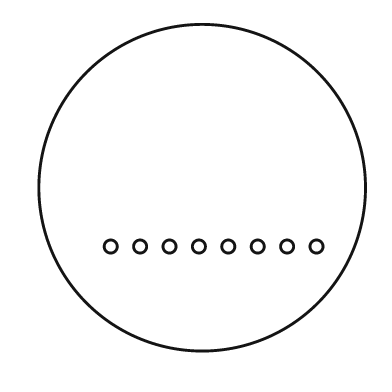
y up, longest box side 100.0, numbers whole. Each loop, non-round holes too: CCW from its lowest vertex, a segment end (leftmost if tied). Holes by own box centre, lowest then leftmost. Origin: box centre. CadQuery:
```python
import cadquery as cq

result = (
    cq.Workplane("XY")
    .moveTo(0.0, 0.0)
    .circle(50.0)
    .moveTo(-28.0, -18.0)
    .circle(2.0)
    .moveTo(-19.0, -18.0)
    .circle(2.0)
    .moveTo(-10.0, -18.0)
    .circle(2.0)
    .moveTo(-1.0, -18.0)
    .circle(2.0)
    .moveTo(8.0, -18.0)
    .circle(2.0)
    .moveTo(17.0, -18.0)
    .circle(2.0)
    .moveTo(26.0, -18.0)
    .circle(2.0)
    .moveTo(35.0, -18.0)
    .circle(2.0)
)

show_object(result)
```